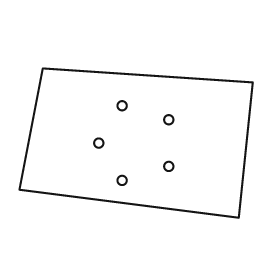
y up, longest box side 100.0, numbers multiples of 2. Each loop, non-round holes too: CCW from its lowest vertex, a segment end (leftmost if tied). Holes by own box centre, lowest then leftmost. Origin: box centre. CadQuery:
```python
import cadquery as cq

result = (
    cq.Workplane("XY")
    .moveTo(44.0, -32.0)
    .lineTo(50.0, 26.0)
    .lineTo(-40.0, 32.0)
    .lineTo(-50.0, -20.0)
    .close()
    .moveTo(-6.0, -16.0)
    .circle(2.0)
    .moveTo(14.0, -10.0)
    .circle(2.0)
    .moveTo(-16.0, 0.0)
    .circle(2.0)
    .moveTo(14.0, 10.0)
    .circle(2.0)
    .moveTo(-6.0, 16.0)
    .circle(2.0)
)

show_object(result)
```